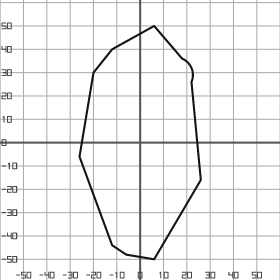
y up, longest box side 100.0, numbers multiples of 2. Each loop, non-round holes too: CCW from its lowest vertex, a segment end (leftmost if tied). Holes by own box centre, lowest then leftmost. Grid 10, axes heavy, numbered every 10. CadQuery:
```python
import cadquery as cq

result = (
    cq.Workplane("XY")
    .moveTo(6.0, -50.0)
    .lineTo(26.0, -16.0)
    .lineTo(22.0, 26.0)
    .threePointArc((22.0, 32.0), (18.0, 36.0))
    .lineTo(6.0, 50.0)
    .lineTo(-12.0, 40.0)
    .lineTo(-20.0, 30.0)
    .lineTo(-26.0, -6.0)
    .lineTo(-12.0, -44.0)
    .lineTo(-6.0, -48.0)
    .close()
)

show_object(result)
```